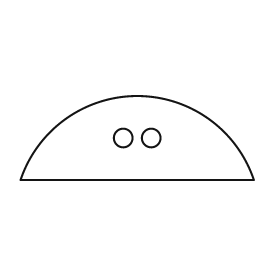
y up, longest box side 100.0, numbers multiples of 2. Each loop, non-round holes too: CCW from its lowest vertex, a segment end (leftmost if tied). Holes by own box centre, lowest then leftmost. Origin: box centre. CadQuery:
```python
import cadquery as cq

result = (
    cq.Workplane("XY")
    .moveTo(-50.0, -18.0)
    .lineTo(50.0, -18.0)
    .threePointArc((0.0, 18.0), (-50.0, -18.0))
    .close()
    .moveTo(-6.0, 0.0)
    .circle(4.0)
    .moveTo(6.0, 0.0)
    .circle(4.0)
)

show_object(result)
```